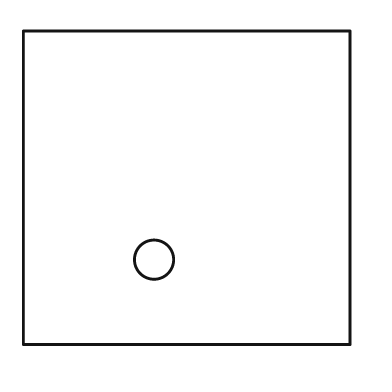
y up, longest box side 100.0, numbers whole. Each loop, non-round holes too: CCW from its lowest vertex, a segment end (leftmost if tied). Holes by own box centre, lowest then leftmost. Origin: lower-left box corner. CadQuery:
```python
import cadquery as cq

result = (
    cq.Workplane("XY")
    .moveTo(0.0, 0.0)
    .lineTo(100.0, 0.0)
    .lineTo(100.0, 96.0)
    .lineTo(0.0, 96.0)
    .close()
    .moveTo(40.0, 26.0)
    .circle(6.0)
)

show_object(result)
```